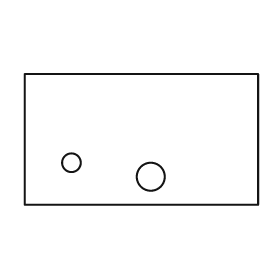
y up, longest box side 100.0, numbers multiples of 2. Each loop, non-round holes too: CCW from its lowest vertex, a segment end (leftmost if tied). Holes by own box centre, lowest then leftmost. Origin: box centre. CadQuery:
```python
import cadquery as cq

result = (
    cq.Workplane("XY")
    .moveTo(-50.0, -28.0)
    .lineTo(50.0, -28.0)
    .lineTo(50.0, 28.0)
    .lineTo(-50.0, 28.0)
    .close()
    .moveTo(4.0, -16.0)
    .circle(6.0)
    .moveTo(-30.0, -10.0)
    .circle(4.0)
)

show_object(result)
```